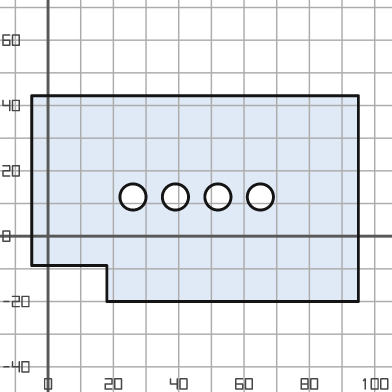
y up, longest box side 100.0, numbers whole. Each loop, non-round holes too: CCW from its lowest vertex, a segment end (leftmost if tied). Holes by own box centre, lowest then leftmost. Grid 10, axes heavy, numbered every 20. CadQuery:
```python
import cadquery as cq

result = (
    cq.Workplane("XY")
    .moveTo(18.0, -20.0)
    .lineTo(95.0, -20.0)
    .lineTo(95.0, 43.0)
    .lineTo(-5.0, 43.0)
    .lineTo(-5.0, -9.0)
    .lineTo(18.0, -9.0)
    .close()
    .moveTo(26.0, 12.0)
    .circle(4.0)
    .moveTo(39.0, 12.0)
    .circle(4.0)
    .moveTo(52.0, 12.0)
    .circle(4.0)
    .moveTo(65.0, 12.0)
    .circle(4.0)
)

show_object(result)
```